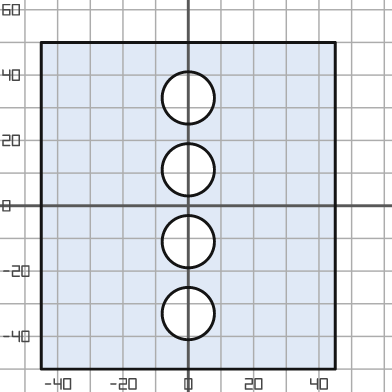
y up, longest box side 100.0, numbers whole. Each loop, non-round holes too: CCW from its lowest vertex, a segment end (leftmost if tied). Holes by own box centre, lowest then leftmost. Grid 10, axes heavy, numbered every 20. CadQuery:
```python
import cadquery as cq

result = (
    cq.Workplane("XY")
    .moveTo(-45.0, -50.0)
    .lineTo(45.0, -50.0)
    .lineTo(45.0, 50.0)
    .lineTo(-45.0, 50.0)
    .close()
    .moveTo(0.0, -33.0)
    .circle(8.0)
    .moveTo(0.0, -11.0)
    .circle(8.0)
    .moveTo(0.0, 11.0)
    .circle(8.0)
    .moveTo(0.0, 33.0)
    .circle(8.0)
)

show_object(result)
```